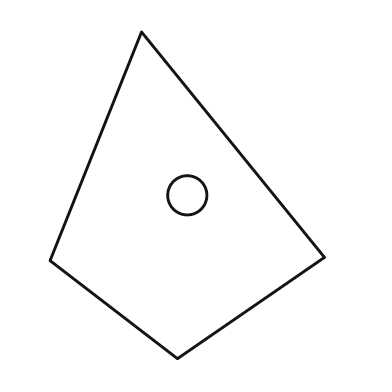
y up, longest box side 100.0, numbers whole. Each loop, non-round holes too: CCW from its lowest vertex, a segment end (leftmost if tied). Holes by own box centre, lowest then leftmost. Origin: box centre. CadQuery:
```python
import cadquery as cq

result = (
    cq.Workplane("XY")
    .moveTo(-3.0, -50.0)
    .lineTo(42.0, -19.0)
    .lineTo(-14.0, 50.0)
    .lineTo(-42.0, -20.0)
    .close()
    .moveTo(0.0, 0.0)
    .circle(6.0)
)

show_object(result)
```